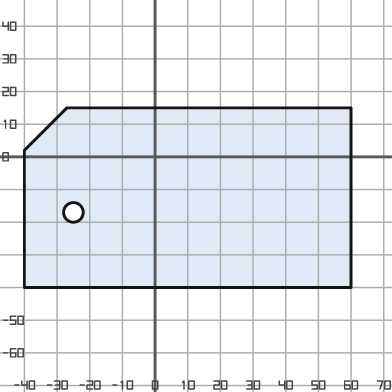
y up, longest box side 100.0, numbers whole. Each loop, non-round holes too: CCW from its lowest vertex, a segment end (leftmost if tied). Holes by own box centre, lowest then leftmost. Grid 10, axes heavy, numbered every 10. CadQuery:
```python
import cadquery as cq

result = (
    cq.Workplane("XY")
    .moveTo(-40.0, -40.0)
    .lineTo(60.0, -40.0)
    .lineTo(60.0, 15.0)
    .lineTo(-27.0, 15.0)
    .lineTo(-40.0, 2.0)
    .close()
    .moveTo(-25.0, -17.0)
    .circle(3.0)
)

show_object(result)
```